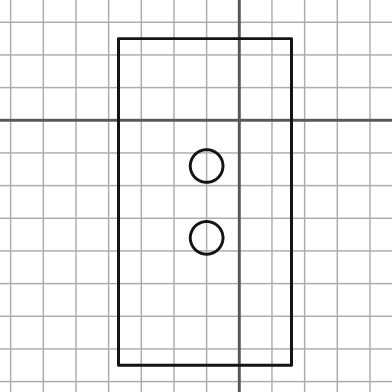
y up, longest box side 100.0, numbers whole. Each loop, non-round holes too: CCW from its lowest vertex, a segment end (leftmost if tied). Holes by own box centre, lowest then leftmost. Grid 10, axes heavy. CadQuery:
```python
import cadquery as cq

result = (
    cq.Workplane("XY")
    .moveTo(-37.0, -75.0)
    .lineTo(16.0, -75.0)
    .lineTo(16.0, 25.0)
    .lineTo(-37.0, 25.0)
    .close()
    .moveTo(-10.0, -36.0)
    .circle(5.0)
    .moveTo(-10.0, -14.0)
    .circle(5.0)
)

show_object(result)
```